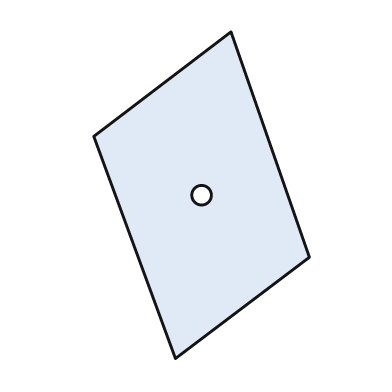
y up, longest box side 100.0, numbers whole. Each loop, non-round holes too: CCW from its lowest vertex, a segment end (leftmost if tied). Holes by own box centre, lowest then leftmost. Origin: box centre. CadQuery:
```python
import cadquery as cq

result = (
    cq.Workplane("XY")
    .moveTo(-8.0, -50.0)
    .lineTo(33.0, -19.0)
    .lineTo(9.0, 50.0)
    .lineTo(-33.0, 18.0)
    .close()
    .moveTo(0.0, 0.0)
    .circle(3.0)
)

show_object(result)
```